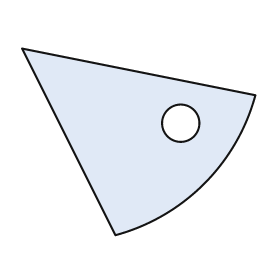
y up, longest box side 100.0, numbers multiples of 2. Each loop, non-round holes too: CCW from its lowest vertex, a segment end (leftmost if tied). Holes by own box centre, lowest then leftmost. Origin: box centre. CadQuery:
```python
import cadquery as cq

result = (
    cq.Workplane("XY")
    .moveTo(-10.0, -40.0)
    .threePointArc((28.0, -18.0), (50.0, 20.0))
    .lineTo(-50.0, 40.0)
    .close()
    .moveTo(18.0, 8.0)
    .circle(8.0)
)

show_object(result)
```